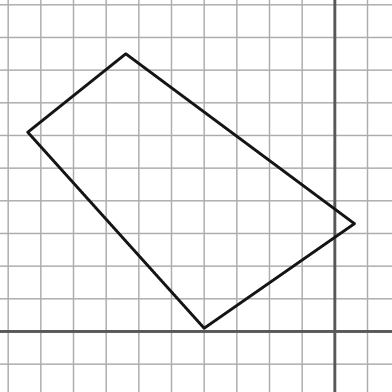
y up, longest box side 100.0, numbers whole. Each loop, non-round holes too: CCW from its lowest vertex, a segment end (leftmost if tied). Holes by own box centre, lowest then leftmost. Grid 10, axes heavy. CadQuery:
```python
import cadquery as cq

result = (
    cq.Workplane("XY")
    .moveTo(-40.0, 1.0)
    .lineTo(6.0, 33.0)
    .lineTo(-64.0, 85.0)
    .lineTo(-94.0, 61.0)
    .close()
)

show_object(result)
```